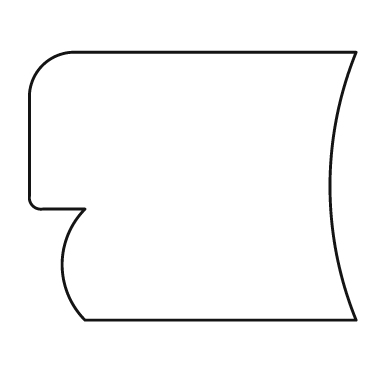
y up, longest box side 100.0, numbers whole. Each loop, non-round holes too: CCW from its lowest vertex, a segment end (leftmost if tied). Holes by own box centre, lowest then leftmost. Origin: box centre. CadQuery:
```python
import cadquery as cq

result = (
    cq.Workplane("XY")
    .moveTo(-33.0, -41.0)
    .lineTo(50.0, -41.0)
    .threePointArc((42.0, 0.0), (50.0, 41.0))
    .lineTo(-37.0, 41.0)
    .threePointArc((-46.0, 37.0), (-50.0, 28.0))
    .lineTo(-50.0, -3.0)
    .threePointArc((-49.0, -6.0), (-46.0, -7.0))
    .lineTo(-33.0, -7.0)
    .threePointArc((-40.0, -24.0), (-33.0, -41.0))
    .close()
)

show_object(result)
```